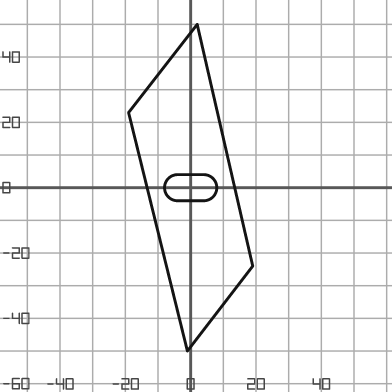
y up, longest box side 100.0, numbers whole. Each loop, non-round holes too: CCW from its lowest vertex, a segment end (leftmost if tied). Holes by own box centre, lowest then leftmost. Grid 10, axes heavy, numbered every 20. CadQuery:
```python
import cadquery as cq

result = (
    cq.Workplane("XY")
    .moveTo(-1.0, -50.0)
    .lineTo(19.0, -24.0)
    .lineTo(2.0, 50.0)
    .lineTo(-19.0, 23.0)
    .close()
    .moveTo(-4.0, -4.0)
    .lineTo(4.0, -4.0)
    .threePointArc((8.0, 0.0), (4.0, 4.0))
    .lineTo(-4.0, 4.0)
    .threePointArc((-8.0, 0.0), (-4.0, -4.0))
    .close()
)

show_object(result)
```